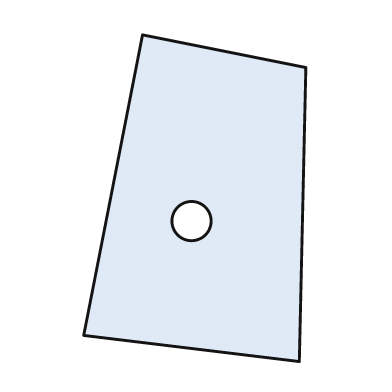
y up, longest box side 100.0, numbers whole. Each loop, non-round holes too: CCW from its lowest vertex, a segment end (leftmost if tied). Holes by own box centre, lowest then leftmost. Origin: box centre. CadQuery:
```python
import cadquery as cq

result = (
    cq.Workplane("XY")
    .moveTo(32.0, -50.0)
    .lineTo(34.0, 40.0)
    .lineTo(-16.0, 50.0)
    .lineTo(-34.0, -42.0)
    .close()
    .moveTo(-1.0, -7.0)
    .circle(6.0)
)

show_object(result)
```